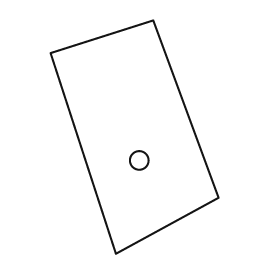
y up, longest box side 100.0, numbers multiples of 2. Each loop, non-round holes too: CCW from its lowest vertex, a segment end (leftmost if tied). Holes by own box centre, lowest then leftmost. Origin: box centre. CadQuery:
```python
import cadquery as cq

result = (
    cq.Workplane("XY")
    .moveTo(-8.0, -50.0)
    .lineTo(36.0, -26.0)
    .lineTo(8.0, 50.0)
    .lineTo(-36.0, 36.0)
    .close()
    .moveTo(2.0, -10.0)
    .circle(4.0)
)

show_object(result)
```